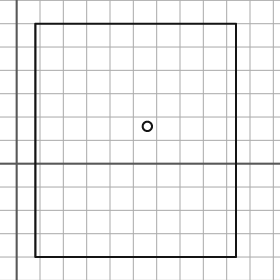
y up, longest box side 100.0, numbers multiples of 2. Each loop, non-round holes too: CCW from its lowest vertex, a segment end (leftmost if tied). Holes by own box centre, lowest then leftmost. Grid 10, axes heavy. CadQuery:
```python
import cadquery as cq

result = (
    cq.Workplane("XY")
    .moveTo(8.0, -40.0)
    .lineTo(94.0, -40.0)
    .lineTo(94.0, 60.0)
    .lineTo(8.0, 60.0)
    .close()
    .moveTo(56.0, 16.0)
    .circle(2.0)
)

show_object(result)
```